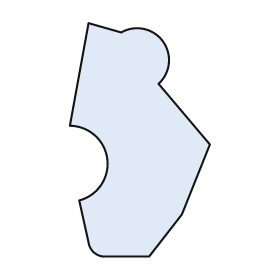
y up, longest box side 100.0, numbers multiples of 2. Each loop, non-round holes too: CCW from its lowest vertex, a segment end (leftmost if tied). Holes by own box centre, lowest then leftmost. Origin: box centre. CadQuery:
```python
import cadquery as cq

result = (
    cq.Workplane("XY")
    .moveTo(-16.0, -50.0)
    .lineTo(4.0, -50.0)
    .lineTo(18.0, -32.0)
    .lineTo(30.0, -2.0)
    .lineTo(8.0, 24.0)
    .threePointArc((10.0, 42.0), (-8.0, 46.0))
    .lineTo(-22.0, 50.0)
    .lineTo(-30.0, 6.0)
    .threePointArc((-14.0, -8.0), (-26.0, -26.0))
    .lineTo(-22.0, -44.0)
    .threePointArc((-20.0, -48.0), (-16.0, -50.0))
    .close()
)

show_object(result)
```